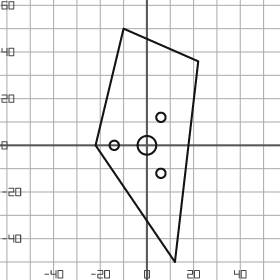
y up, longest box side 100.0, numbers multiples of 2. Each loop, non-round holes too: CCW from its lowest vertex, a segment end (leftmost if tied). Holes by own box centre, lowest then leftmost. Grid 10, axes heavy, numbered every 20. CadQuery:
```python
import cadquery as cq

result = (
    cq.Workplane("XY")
    .moveTo(12.0, -50.0)
    .lineTo(22.0, 36.0)
    .lineTo(-10.0, 50.0)
    .lineTo(-22.0, 0.0)
    .close()
    .moveTo(6.0, -12.0)
    .circle(2.0)
    .moveTo(-14.0, 0.0)
    .circle(2.0)
    .moveTo(0.0, 0.0)
    .circle(4.0)
    .moveTo(6.0, 12.0)
    .circle(2.0)
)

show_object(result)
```